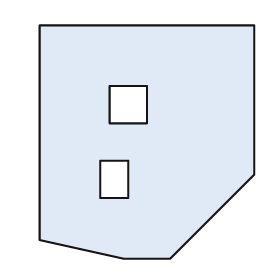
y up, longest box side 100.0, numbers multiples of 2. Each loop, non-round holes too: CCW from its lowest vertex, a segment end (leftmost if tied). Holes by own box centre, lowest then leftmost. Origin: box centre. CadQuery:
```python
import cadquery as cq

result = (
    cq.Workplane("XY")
    .moveTo(-10.0, -50.0)
    .lineTo(10.0, -50.0)
    .lineTo(46.0, -14.0)
    .lineTo(46.0, 50.0)
    .lineTo(-46.0, 50.0)
    .lineTo(-46.0, -42.0)
    .close()
    .moveTo(-20.0, -24.0)
    .lineTo(-8.0, -24.0)
    .lineTo(-8.0, -8.0)
    .lineTo(-20.0, -8.0)
    .close()
    .moveTo(-16.0, 8.0)
    .lineTo(0.0, 8.0)
    .lineTo(0.0, 24.0)
    .lineTo(-16.0, 24.0)
    .close()
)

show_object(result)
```